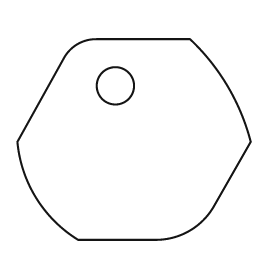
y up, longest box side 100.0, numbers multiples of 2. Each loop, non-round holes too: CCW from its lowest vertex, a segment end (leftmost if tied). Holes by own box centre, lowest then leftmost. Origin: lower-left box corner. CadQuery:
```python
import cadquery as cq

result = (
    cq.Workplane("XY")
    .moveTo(26.0, 0.0)
    .lineTo(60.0, 0.0)
    .threePointArc((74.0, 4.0), (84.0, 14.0))
    .lineTo(100.0, 42.0)
    .threePointArc((90.0, 66.0), (74.0, 86.0))
    .lineTo(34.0, 86.0)
    .threePointArc((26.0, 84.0), (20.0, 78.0))
    .lineTo(0.0, 42.0)
    .threePointArc((8.0, 18.0), (26.0, 0.0))
    .close()
    .moveTo(42.0, 66.0)
    .circle(8.0)
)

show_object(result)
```